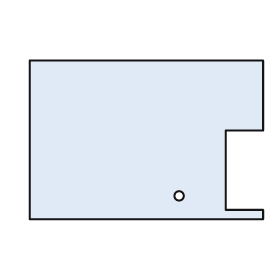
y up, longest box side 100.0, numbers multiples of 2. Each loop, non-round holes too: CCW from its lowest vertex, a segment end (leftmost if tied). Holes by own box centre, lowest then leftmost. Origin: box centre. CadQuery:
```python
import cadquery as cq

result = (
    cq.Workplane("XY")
    .moveTo(-50.0, -34.0)
    .lineTo(50.0, -34.0)
    .lineTo(50.0, -30.0)
    .lineTo(34.0, -30.0)
    .lineTo(34.0, 4.0)
    .lineTo(50.0, 4.0)
    .lineTo(50.0, 34.0)
    .lineTo(-50.0, 34.0)
    .close()
    .moveTo(14.0, -24.0)
    .circle(2.0)
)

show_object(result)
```